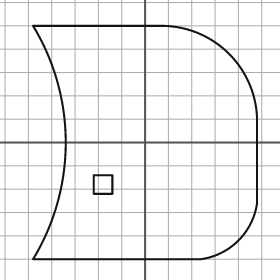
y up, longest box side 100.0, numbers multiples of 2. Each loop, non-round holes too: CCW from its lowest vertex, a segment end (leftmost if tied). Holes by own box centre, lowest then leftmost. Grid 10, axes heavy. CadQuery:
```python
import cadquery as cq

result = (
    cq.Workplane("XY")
    .moveTo(-48.0, -50.0)
    .lineTo(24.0, -50.0)
    .threePointArc((40.0, -42.0), (48.0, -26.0))
    .lineTo(48.0, 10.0)
    .threePointArc((36.0, 38.0), (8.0, 50.0))
    .lineTo(-48.0, 50.0)
    .threePointArc((-34.0, 0.0), (-48.0, -50.0))
    .close()
    .moveTo(-22.0, -22.0)
    .lineTo(-14.0, -22.0)
    .lineTo(-14.0, -14.0)
    .lineTo(-22.0, -14.0)
    .close()
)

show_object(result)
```